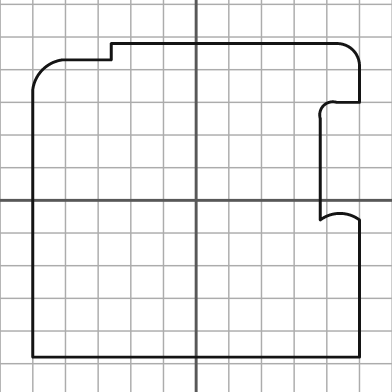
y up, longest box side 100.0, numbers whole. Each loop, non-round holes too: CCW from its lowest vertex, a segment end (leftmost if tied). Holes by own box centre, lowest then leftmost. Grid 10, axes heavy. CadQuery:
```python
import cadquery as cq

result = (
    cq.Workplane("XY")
    .moveTo(-50.0, -48.0)
    .lineTo(50.0, -48.0)
    .lineTo(50.0, -6.0)
    .threePointArc((44.0, -4.0), (38.0, -6.0))
    .lineTo(38.0, 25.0)
    .threePointArc((39.0, 29.0), (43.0, 30.0))
    .lineTo(50.0, 30.0)
    .lineTo(50.0, 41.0)
    .threePointArc((48.0, 46.0), (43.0, 48.0))
    .lineTo(-26.0, 48.0)
    .lineTo(-26.0, 43.0)
    .lineTo(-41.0, 43.0)
    .threePointArc((-47.0, 40.0), (-50.0, 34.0))
    .close()
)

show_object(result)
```